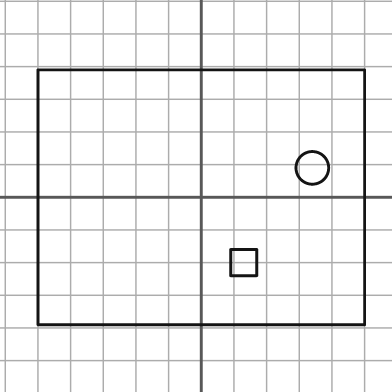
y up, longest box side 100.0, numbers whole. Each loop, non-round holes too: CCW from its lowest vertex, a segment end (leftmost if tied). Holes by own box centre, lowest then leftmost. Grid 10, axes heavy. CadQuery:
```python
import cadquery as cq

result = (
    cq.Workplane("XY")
    .moveTo(-50.0, -39.0)
    .lineTo(50.0, -39.0)
    .lineTo(50.0, 39.0)
    .lineTo(-50.0, 39.0)
    .close()
    .moveTo(9.0, -24.0)
    .lineTo(17.0, -24.0)
    .lineTo(17.0, -16.0)
    .lineTo(9.0, -16.0)
    .close()
    .moveTo(34.0, 9.0)
    .circle(5.0)
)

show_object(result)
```